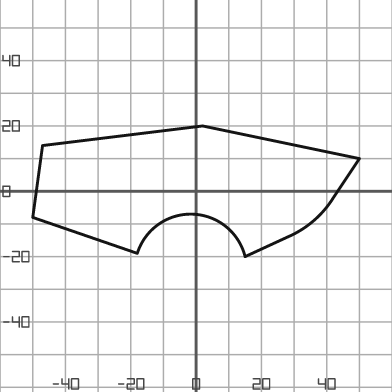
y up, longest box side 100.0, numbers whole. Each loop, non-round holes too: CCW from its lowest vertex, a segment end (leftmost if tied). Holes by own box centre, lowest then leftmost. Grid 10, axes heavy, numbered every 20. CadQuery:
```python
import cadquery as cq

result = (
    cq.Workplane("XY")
    .moveTo(15.0, -20.0)
    .lineTo(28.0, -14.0)
    .threePointArc((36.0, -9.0), (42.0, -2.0))
    .lineTo(50.0, 10.0)
    .lineTo(2.0, 20.0)
    .lineTo(-47.0, 14.0)
    .lineTo(-50.0, -8.0)
    .lineTo(-18.0, -19.0)
    .threePointArc((-1.0, -7.0), (15.0, -20.0))
    .close()
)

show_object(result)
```